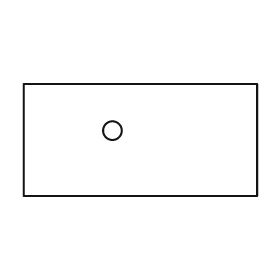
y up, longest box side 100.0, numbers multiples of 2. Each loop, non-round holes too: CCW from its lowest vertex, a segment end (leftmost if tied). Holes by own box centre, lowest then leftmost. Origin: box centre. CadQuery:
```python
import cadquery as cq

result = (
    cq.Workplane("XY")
    .moveTo(-50.0, -24.0)
    .lineTo(50.0, -24.0)
    .lineTo(50.0, 24.0)
    .lineTo(-50.0, 24.0)
    .close()
    .moveTo(-12.0, 4.0)
    .circle(4.0)
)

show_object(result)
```